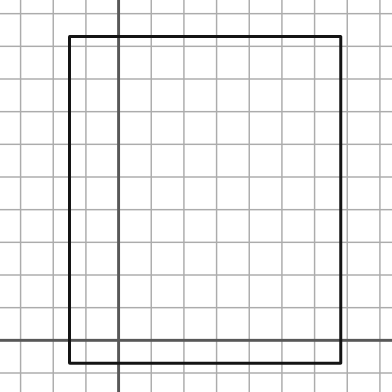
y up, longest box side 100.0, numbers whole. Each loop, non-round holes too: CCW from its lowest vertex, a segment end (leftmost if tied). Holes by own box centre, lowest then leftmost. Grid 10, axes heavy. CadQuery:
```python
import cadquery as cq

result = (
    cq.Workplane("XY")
    .moveTo(-15.0, -7.0)
    .lineTo(68.0, -7.0)
    .lineTo(68.0, 93.0)
    .lineTo(-15.0, 93.0)
    .close()
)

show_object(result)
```